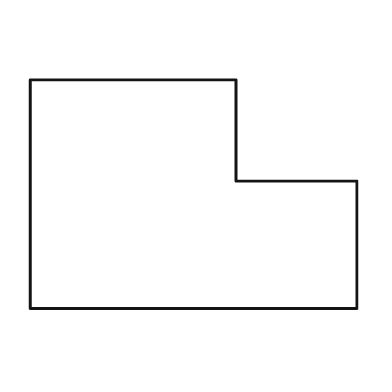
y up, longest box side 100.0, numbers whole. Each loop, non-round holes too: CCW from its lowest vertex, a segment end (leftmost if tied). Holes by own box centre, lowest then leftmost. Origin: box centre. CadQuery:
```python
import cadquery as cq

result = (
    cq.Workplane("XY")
    .moveTo(-50.0, -35.0)
    .lineTo(50.0, -35.0)
    .lineTo(50.0, 4.0)
    .lineTo(13.0, 4.0)
    .lineTo(13.0, 35.0)
    .lineTo(-50.0, 35.0)
    .close()
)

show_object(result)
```